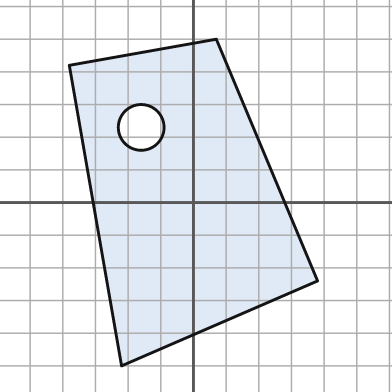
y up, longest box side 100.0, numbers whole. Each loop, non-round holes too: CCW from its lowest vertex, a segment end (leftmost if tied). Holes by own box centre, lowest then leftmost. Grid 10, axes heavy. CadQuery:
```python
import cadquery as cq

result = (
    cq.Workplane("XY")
    .moveTo(-22.0, -50.0)
    .lineTo(38.0, -24.0)
    .lineTo(7.0, 50.0)
    .lineTo(-38.0, 42.0)
    .close()
    .moveTo(-16.0, 23.0)
    .circle(7.0)
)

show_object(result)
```